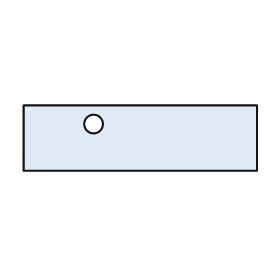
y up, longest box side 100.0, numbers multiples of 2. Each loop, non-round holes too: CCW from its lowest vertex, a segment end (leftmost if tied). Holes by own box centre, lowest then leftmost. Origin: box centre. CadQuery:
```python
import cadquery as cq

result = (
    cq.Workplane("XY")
    .moveTo(-50.0, -14.0)
    .lineTo(50.0, -14.0)
    .lineTo(50.0, 14.0)
    .lineTo(-50.0, 14.0)
    .close()
    .moveTo(-20.0, 6.0)
    .circle(4.0)
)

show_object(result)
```